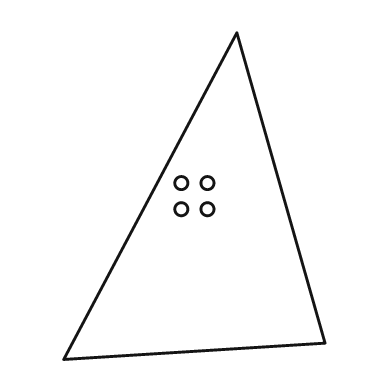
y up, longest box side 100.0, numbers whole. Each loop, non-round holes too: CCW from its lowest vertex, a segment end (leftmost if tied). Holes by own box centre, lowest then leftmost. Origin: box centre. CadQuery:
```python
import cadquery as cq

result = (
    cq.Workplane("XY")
    .moveTo(-40.0, -50.0)
    .lineTo(40.0, -45.0)
    .lineTo(13.0, 50.0)
    .close()
    .moveTo(-4.0, -4.0)
    .circle(2.0)
    .moveTo(4.0, -4.0)
    .circle(2.0)
    .moveTo(-4.0, 4.0)
    .circle(2.0)
    .moveTo(4.0, 4.0)
    .circle(2.0)
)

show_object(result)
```